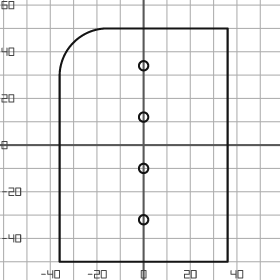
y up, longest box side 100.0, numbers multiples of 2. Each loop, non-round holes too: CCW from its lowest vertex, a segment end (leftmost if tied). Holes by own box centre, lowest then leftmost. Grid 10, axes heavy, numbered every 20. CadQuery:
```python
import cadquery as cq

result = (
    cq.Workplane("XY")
    .moveTo(-36.0, -50.0)
    .lineTo(36.0, -50.0)
    .lineTo(36.0, 50.0)
    .lineTo(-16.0, 50.0)
    .threePointArc((-30.0, 44.0), (-36.0, 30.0))
    .close()
    .moveTo(0.0, -32.0)
    .circle(2.0)
    .moveTo(0.0, -10.0)
    .circle(2.0)
    .moveTo(0.0, 12.0)
    .circle(2.0)
    .moveTo(0.0, 34.0)
    .circle(2.0)
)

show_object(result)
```